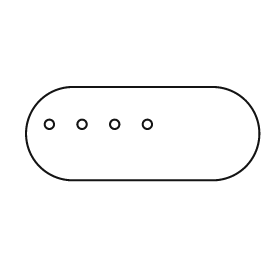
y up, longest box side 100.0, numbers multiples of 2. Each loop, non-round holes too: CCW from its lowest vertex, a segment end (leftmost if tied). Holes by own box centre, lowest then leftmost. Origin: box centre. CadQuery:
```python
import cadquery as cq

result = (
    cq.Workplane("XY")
    .moveTo(-30.0, -20.0)
    .lineTo(30.0, -20.0)
    .threePointArc((50.0, 0.0), (30.0, 20.0))
    .lineTo(-30.0, 20.0)
    .threePointArc((-50.0, 0.0), (-30.0, -20.0))
    .close()
    .moveTo(-40.0, 4.0)
    .circle(2.0)
    .moveTo(-26.0, 4.0)
    .circle(2.0)
    .moveTo(-12.0, 4.0)
    .circle(2.0)
    .moveTo(2.0, 4.0)
    .circle(2.0)
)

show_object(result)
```